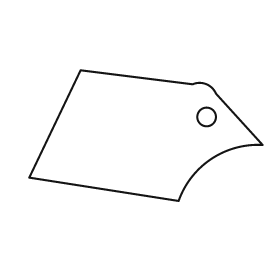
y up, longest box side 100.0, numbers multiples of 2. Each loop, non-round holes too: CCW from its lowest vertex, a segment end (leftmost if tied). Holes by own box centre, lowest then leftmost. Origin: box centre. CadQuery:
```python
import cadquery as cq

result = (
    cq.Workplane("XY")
    .moveTo(14.0, -28.0)
    .threePointArc((28.0, -10.0), (50.0, -4.0))
    .lineTo(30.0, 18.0)
    .threePointArc((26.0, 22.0), (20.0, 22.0))
    .lineTo(-28.0, 28.0)
    .lineTo(-50.0, -18.0)
    .close()
    .moveTo(26.0, 8.0)
    .circle(4.0)
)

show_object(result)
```